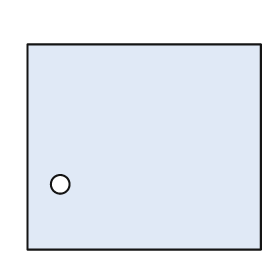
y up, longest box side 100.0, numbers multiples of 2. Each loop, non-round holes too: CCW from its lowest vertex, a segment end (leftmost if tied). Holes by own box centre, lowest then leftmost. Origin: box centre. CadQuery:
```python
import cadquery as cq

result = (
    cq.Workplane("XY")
    .moveTo(-50.0, -44.0)
    .lineTo(50.0, -44.0)
    .lineTo(50.0, 44.0)
    .lineTo(-50.0, 44.0)
    .close()
    .moveTo(-36.0, -16.0)
    .circle(4.0)
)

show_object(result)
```